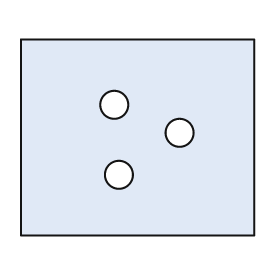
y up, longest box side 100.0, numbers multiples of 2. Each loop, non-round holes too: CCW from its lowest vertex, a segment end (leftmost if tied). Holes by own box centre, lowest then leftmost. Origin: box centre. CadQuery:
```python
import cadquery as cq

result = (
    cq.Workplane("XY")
    .moveTo(-50.0, -42.0)
    .lineTo(50.0, -42.0)
    .lineTo(50.0, 42.0)
    .lineTo(-50.0, 42.0)
    .close()
    .moveTo(-8.0, -16.0)
    .circle(6.0)
    .moveTo(18.0, 2.0)
    .circle(6.0)
    .moveTo(-10.0, 14.0)
    .circle(6.0)
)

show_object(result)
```